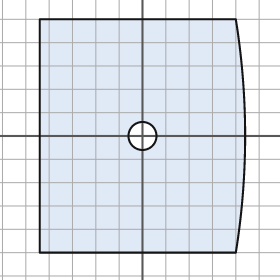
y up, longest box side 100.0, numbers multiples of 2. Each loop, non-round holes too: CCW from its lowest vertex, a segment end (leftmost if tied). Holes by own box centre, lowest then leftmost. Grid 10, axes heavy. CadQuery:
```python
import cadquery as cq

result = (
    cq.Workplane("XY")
    .moveTo(-44.0, -50.0)
    .lineTo(40.0, -50.0)
    .threePointArc((44.0, 0.0), (40.0, 50.0))
    .lineTo(-44.0, 50.0)
    .close()
    .moveTo(0.0, 0.0)
    .circle(6.0)
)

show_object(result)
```